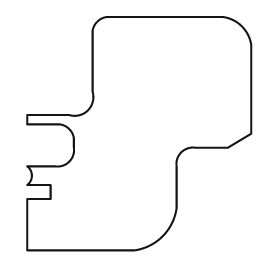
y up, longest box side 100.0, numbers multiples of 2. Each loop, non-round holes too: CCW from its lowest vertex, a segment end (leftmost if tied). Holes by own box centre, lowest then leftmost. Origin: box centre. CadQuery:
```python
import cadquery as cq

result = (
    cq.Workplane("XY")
    .moveTo(-48.0, -50.0)
    .lineTo(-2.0, -50.0)
    .threePointArc((10.0, -44.0), (16.0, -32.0))
    .lineTo(16.0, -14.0)
    .threePointArc((18.0, -8.0), (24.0, -6.0))
    .lineTo(38.0, -6.0)
    .lineTo(48.0, 0.0)
    .lineTo(48.0, 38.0)
    .threePointArc((44.0, 46.0), (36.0, 50.0))
    .lineTo(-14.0, 50.0)
    .threePointArc((-18.0, 48.0), (-20.0, 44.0))
    .lineTo(-20.0, 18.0)
    .threePointArc((-22.0, 10.0), (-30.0, 8.0))
    .lineTo(-48.0, 8.0)
    .lineTo(-48.0, 4.0)
    .lineTo(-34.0, 4.0)
    .threePointArc((-30.0, 2.0), (-28.0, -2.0))
    .lineTo(-28.0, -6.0)
    .threePointArc((-30.0, -12.0), (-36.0, -14.0))
    .lineTo(-48.0, -14.0)
    .threePointArc((-46.0, -18.0), (-48.0, -22.0))
    .lineTo(-38.0, -22.0)
    .lineTo(-38.0, -28.0)
    .lineTo(-48.0, -28.0)
    .close()
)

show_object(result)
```